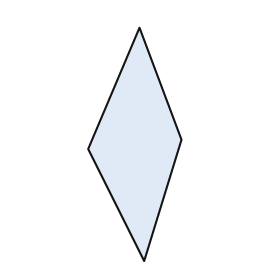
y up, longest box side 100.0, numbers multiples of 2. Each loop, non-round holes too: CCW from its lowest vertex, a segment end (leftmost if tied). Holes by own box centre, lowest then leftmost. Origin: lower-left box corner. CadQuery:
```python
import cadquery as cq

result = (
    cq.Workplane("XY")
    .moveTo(24.0, 0.0)
    .lineTo(40.0, 52.0)
    .lineTo(22.0, 100.0)
    .lineTo(0.0, 48.0)
    .close()
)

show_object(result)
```